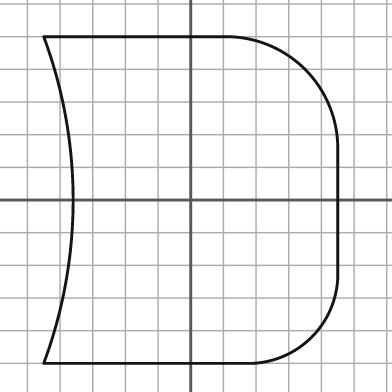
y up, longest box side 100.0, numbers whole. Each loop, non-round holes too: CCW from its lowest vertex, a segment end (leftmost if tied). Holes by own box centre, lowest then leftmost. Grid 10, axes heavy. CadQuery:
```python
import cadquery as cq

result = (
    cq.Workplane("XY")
    .moveTo(-45.0, -50.0)
    .lineTo(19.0, -50.0)
    .threePointArc((37.0, -42.0), (45.0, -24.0))
    .lineTo(45.0, 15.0)
    .threePointArc((35.0, 40.0), (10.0, 50.0))
    .lineTo(-45.0, 50.0)
    .threePointArc((-36.0, 0.0), (-45.0, -50.0))
    .close()
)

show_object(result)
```